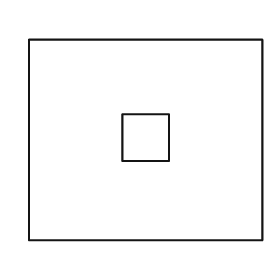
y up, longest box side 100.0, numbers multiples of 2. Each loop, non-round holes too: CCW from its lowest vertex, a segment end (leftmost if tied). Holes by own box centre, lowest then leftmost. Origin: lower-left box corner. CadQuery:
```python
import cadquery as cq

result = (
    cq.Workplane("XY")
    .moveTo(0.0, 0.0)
    .lineTo(100.0, 0.0)
    .lineTo(100.0, 86.0)
    .lineTo(0.0, 86.0)
    .close()
    .moveTo(40.0, 34.0)
    .lineTo(60.0, 34.0)
    .lineTo(60.0, 54.0)
    .lineTo(40.0, 54.0)
    .close()
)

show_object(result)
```